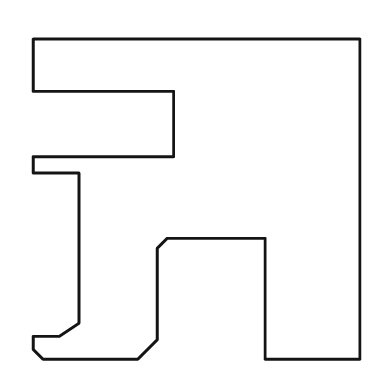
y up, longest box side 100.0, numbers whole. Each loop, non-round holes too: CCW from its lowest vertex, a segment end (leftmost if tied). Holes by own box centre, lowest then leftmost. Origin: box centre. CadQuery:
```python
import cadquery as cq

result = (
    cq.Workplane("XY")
    .moveTo(-47.0, -49.0)
    .lineTo(-18.0, -49.0)
    .lineTo(-12.0, -43.0)
    .lineTo(-12.0, -15.0)
    .lineTo(-9.0, -12.0)
    .lineTo(21.0, -12.0)
    .lineTo(21.0, -49.0)
    .lineTo(50.0, -49.0)
    .lineTo(50.0, 49.0)
    .lineTo(-50.0, 49.0)
    .lineTo(-50.0, 33.0)
    .lineTo(-7.0, 33.0)
    .lineTo(-7.0, 13.0)
    .lineTo(-50.0, 13.0)
    .lineTo(-50.0, 8.0)
    .lineTo(-36.0, 8.0)
    .lineTo(-36.0, -38.0)
    .lineTo(-42.0, -42.0)
    .lineTo(-50.0, -42.0)
    .lineTo(-50.0, -46.0)
    .close()
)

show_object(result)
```